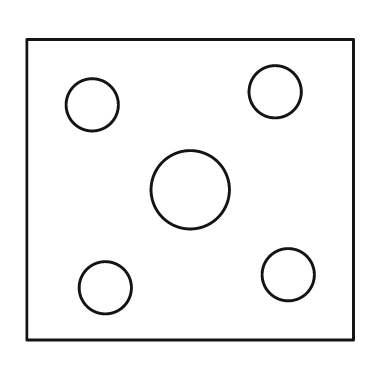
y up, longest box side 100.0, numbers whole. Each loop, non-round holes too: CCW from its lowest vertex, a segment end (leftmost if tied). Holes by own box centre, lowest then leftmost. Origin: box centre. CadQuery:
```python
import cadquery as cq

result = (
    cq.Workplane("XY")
    .moveTo(-50.0, -46.0)
    .lineTo(50.0, -46.0)
    .lineTo(50.0, 46.0)
    .lineTo(-50.0, 46.0)
    .close()
    .moveTo(-26.0, -30.0)
    .circle(8.0)
    .moveTo(30.0, -26.0)
    .circle(8.0)
    .moveTo(0.0, 0.0)
    .circle(12.0)
    .moveTo(-30.0, 26.0)
    .circle(8.0)
    .moveTo(26.0, 30.0)
    .circle(8.0)
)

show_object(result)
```